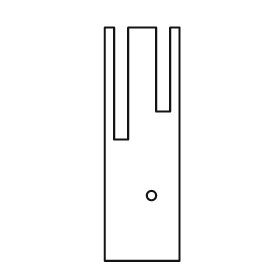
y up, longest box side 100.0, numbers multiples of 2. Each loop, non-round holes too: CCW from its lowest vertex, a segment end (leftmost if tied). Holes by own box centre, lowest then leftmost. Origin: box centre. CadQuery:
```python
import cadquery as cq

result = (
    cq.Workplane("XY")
    .moveTo(-16.0, -50.0)
    .lineTo(16.0, -50.0)
    .lineTo(16.0, 50.0)
    .lineTo(12.0, 50.0)
    .lineTo(12.0, 14.0)
    .lineTo(6.0, 14.0)
    .lineTo(6.0, 50.0)
    .lineTo(-6.0, 50.0)
    .lineTo(-6.0, 2.0)
    .lineTo(-12.0, 2.0)
    .lineTo(-12.0, 50.0)
    .lineTo(-16.0, 50.0)
    .close()
    .moveTo(4.0, -22.0)
    .circle(2.0)
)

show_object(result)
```